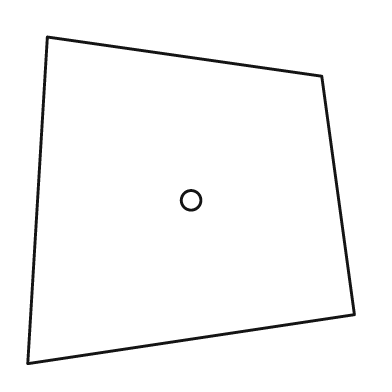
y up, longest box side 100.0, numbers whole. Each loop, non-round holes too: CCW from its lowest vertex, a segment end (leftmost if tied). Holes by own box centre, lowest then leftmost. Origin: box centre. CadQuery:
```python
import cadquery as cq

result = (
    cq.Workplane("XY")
    .moveTo(-50.0, -50.0)
    .lineTo(50.0, -35.0)
    .lineTo(40.0, 38.0)
    .lineTo(-44.0, 50.0)
    .close()
    .moveTo(0.0, 0.0)
    .circle(3.0)
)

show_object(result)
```